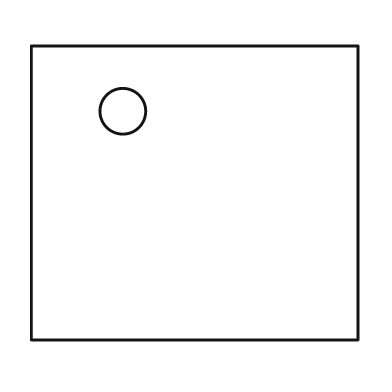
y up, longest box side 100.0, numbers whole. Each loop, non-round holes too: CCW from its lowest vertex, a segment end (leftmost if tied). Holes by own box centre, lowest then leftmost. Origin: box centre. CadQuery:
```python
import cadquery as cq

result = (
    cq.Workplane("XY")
    .moveTo(-50.0, -45.0)
    .lineTo(50.0, -45.0)
    .lineTo(50.0, 45.0)
    .lineTo(-50.0, 45.0)
    .close()
    .moveTo(-22.0, 25.0)
    .circle(7.0)
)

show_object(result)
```